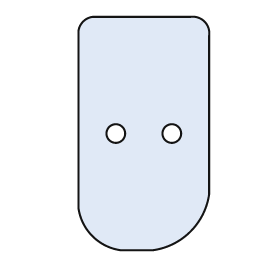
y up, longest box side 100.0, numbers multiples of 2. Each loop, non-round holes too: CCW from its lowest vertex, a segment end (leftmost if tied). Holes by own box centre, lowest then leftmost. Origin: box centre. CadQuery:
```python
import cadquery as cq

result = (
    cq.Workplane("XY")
    .moveTo(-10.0, -50.0)
    .lineTo(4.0, -50.0)
    .threePointArc((20.0, -42.0), (28.0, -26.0))
    .lineTo(28.0, 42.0)
    .threePointArc((26.0, 48.0), (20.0, 50.0))
    .lineTo(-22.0, 50.0)
    .threePointArc((-26.0, 48.0), (-28.0, 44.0))
    .lineTo(-28.0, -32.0)
    .threePointArc((-22.0, -44.0), (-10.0, -50.0))
    .close()
    .moveTo(-12.0, 0.0)
    .circle(4.0)
    .moveTo(12.0, 0.0)
    .circle(4.0)
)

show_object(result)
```